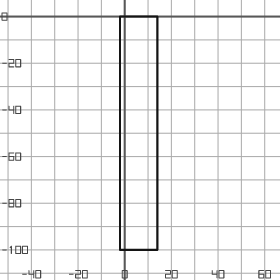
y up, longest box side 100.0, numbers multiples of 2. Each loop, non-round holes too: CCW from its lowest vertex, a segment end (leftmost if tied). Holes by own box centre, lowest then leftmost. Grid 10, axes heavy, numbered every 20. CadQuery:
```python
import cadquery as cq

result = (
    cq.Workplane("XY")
    .moveTo(-2.0, -100.0)
    .lineTo(14.0, -100.0)
    .lineTo(14.0, 0.0)
    .lineTo(-2.0, 0.0)
    .close()
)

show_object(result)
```